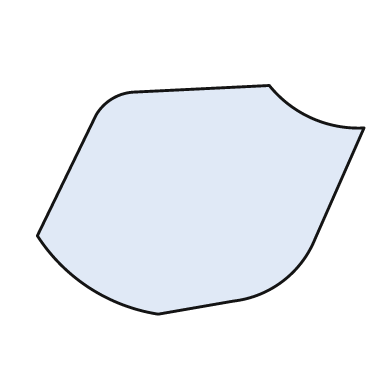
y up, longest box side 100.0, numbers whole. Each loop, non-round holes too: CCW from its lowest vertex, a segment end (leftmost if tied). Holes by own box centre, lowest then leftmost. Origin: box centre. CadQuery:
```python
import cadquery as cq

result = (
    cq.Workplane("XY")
    .moveTo(-13.0, -35.0)
    .lineTo(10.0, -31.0)
    .threePointArc((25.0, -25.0), (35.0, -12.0))
    .lineTo(50.0, 22.0)
    .threePointArc((34.0, 25.0), (21.0, 35.0))
    .lineTo(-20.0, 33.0)
    .threePointArc((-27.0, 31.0), (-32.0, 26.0))
    .lineTo(-50.0, -11.0)
    .threePointArc((-34.0, -27.0), (-13.0, -35.0))
    .close()
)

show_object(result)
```